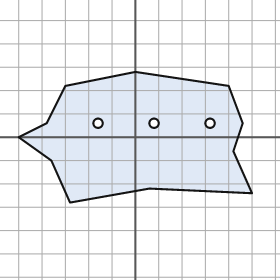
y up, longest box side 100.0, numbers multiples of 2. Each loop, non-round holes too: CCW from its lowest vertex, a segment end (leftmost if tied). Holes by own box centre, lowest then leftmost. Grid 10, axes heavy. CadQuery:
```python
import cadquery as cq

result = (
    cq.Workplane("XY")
    .moveTo(-28.0, -28.0)
    .lineTo(6.0, -22.0)
    .lineTo(50.0, -24.0)
    .lineTo(42.0, -6.0)
    .lineTo(46.0, 6.0)
    .lineTo(40.0, 22.0)
    .lineTo(0.0, 28.0)
    .lineTo(-30.0, 22.0)
    .lineTo(-38.0, 6.0)
    .lineTo(-50.0, 0.0)
    .lineTo(-36.0, -10.0)
    .close()
    .moveTo(-16.0, 6.0)
    .circle(2.0)
    .moveTo(8.0, 6.0)
    .circle(2.0)
    .moveTo(32.0, 6.0)
    .circle(2.0)
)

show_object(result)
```